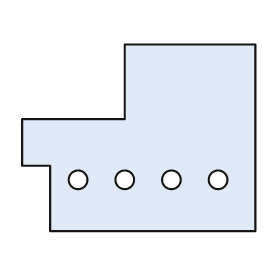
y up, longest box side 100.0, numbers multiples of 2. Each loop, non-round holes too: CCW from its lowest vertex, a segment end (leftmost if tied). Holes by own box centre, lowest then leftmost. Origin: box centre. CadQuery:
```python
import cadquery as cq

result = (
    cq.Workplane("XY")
    .moveTo(-38.0, -40.0)
    .lineTo(50.0, -40.0)
    .lineTo(50.0, 40.0)
    .lineTo(-6.0, 40.0)
    .lineTo(-6.0, 8.0)
    .lineTo(-50.0, 8.0)
    .lineTo(-50.0, -12.0)
    .lineTo(-38.0, -12.0)
    .close()
    .moveTo(-26.0, -18.0)
    .circle(4.0)
    .moveTo(-6.0, -18.0)
    .circle(4.0)
    .moveTo(14.0, -18.0)
    .circle(4.0)
    .moveTo(34.0, -18.0)
    .circle(4.0)
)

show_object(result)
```